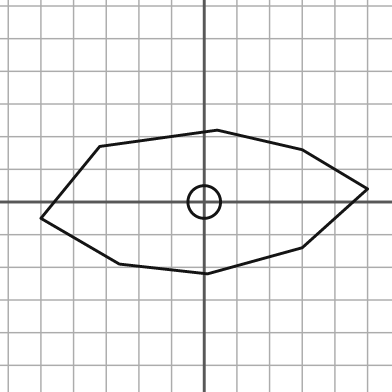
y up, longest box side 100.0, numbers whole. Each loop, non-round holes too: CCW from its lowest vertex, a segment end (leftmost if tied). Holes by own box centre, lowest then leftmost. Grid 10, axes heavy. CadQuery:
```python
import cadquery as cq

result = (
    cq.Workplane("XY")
    .moveTo(1.0, -22.0)
    .lineTo(30.0, -14.0)
    .lineTo(50.0, 4.0)
    .lineTo(30.0, 16.0)
    .lineTo(4.0, 22.0)
    .lineTo(-32.0, 17.0)
    .lineTo(-50.0, -5.0)
    .lineTo(-26.0, -19.0)
    .close()
    .moveTo(0.0, 0.0)
    .circle(5.0)
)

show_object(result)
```